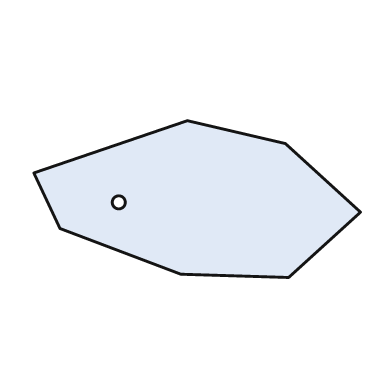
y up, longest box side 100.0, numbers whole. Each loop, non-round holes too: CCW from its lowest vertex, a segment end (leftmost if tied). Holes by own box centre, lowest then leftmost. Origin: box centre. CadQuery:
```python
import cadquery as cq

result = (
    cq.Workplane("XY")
    .moveTo(28.0, -24.0)
    .lineTo(50.0, -4.0)
    .lineTo(27.0, 17.0)
    .lineTo(-3.0, 24.0)
    .lineTo(-50.0, 8.0)
    .lineTo(-42.0, -9.0)
    .lineTo(-5.0, -23.0)
    .close()
    .moveTo(-24.0, -1.0)
    .circle(2.0)
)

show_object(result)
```